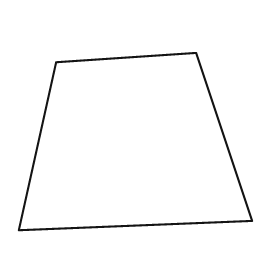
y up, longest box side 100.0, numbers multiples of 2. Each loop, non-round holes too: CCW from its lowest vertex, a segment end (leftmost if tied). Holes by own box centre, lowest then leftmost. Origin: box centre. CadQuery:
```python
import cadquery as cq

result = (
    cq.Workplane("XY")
    .moveTo(-50.0, -38.0)
    .lineTo(50.0, -34.0)
    .lineTo(26.0, 38.0)
    .lineTo(-34.0, 34.0)
    .close()
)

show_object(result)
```